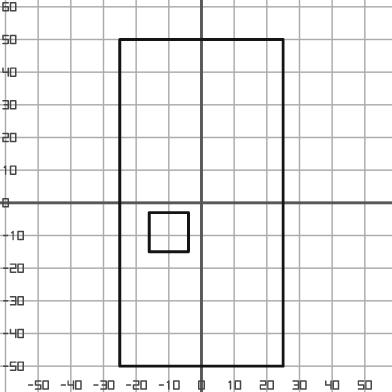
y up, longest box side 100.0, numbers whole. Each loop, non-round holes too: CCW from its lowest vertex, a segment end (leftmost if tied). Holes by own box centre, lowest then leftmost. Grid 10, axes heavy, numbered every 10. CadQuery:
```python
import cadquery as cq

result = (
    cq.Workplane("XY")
    .moveTo(-25.0, -50.0)
    .lineTo(25.0, -50.0)
    .lineTo(25.0, 50.0)
    .lineTo(-25.0, 50.0)
    .close()
    .moveTo(-16.0, -15.0)
    .lineTo(-4.0, -15.0)
    .lineTo(-4.0, -3.0)
    .lineTo(-16.0, -3.0)
    .close()
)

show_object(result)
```